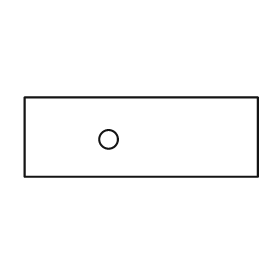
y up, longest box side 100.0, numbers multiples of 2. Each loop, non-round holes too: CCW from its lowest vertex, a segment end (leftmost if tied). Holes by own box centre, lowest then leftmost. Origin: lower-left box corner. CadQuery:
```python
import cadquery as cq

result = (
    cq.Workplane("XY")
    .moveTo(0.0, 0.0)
    .lineTo(100.0, 0.0)
    .lineTo(100.0, 34.0)
    .lineTo(0.0, 34.0)
    .close()
    .moveTo(36.0, 16.0)
    .circle(4.0)
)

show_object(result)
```